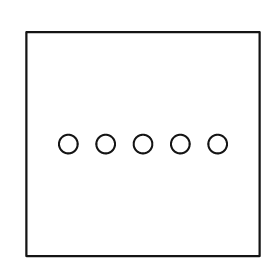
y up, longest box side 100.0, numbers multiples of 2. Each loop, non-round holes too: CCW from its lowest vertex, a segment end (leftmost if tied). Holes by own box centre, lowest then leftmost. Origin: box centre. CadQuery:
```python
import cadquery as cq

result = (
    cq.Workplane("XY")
    .moveTo(-50.0, -48.0)
    .lineTo(50.0, -48.0)
    .lineTo(50.0, 48.0)
    .lineTo(-50.0, 48.0)
    .close()
    .moveTo(-32.0, 0.0)
    .circle(4.0)
    .moveTo(-16.0, 0.0)
    .circle(4.0)
    .moveTo(0.0, 0.0)
    .circle(4.0)
    .moveTo(16.0, 0.0)
    .circle(4.0)
    .moveTo(32.0, 0.0)
    .circle(4.0)
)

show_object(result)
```